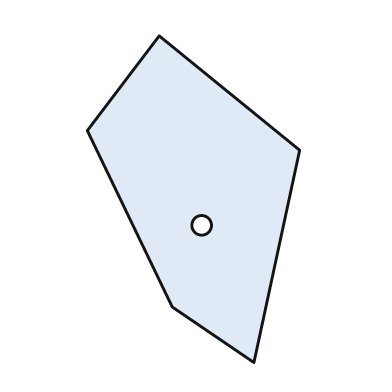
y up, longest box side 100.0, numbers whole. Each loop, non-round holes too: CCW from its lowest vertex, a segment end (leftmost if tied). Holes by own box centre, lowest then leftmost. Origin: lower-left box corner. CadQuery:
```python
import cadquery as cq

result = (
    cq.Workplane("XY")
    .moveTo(51.0, 0.0)
    .lineTo(65.0, 65.0)
    .lineTo(22.0, 100.0)
    .lineTo(0.0, 71.0)
    .lineTo(26.0, 17.0)
    .close()
    .moveTo(35.0, 42.0)
    .circle(3.0)
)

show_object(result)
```